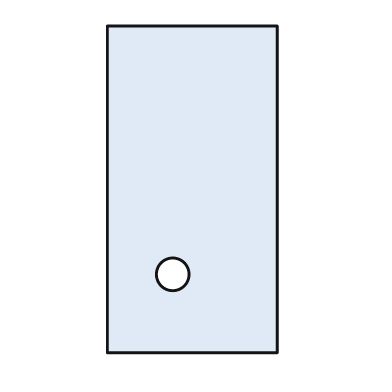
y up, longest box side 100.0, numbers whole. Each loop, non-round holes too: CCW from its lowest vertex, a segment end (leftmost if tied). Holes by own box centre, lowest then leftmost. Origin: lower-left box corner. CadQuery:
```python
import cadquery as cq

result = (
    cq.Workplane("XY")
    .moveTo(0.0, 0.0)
    .lineTo(52.0, 0.0)
    .lineTo(52.0, 100.0)
    .lineTo(0.0, 100.0)
    .close()
    .moveTo(20.0, 24.0)
    .circle(5.0)
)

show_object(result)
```